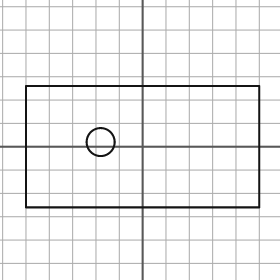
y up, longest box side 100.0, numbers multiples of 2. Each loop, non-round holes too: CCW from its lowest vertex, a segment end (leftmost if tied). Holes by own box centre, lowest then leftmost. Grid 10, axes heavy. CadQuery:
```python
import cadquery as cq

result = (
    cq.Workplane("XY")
    .moveTo(-50.0, -26.0)
    .lineTo(50.0, -26.0)
    .lineTo(50.0, 26.0)
    .lineTo(-50.0, 26.0)
    .close()
    .moveTo(-18.0, 2.0)
    .circle(6.0)
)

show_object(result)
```